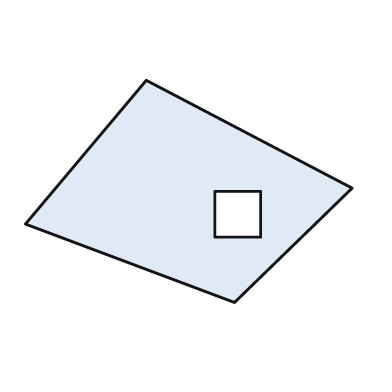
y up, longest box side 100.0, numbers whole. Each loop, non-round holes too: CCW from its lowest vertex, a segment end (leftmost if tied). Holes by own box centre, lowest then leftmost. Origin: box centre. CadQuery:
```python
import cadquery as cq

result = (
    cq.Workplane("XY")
    .moveTo(14.0, -34.0)
    .lineTo(50.0, 1.0)
    .lineTo(-13.0, 34.0)
    .lineTo(-50.0, -10.0)
    .close()
    .moveTo(8.0, -14.0)
    .lineTo(22.0, -14.0)
    .lineTo(22.0, 0.0)
    .lineTo(8.0, 0.0)
    .close()
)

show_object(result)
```